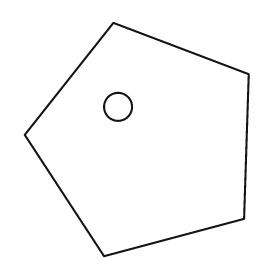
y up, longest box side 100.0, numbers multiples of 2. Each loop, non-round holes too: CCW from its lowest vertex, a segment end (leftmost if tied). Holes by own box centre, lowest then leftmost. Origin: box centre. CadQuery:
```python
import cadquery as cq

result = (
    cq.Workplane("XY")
    .moveTo(-14.0, -50.0)
    .lineTo(46.0, -34.0)
    .lineTo(48.0, 28.0)
    .lineTo(-10.0, 50.0)
    .lineTo(-48.0, 2.0)
    .close()
    .moveTo(-8.0, 14.0)
    .circle(6.0)
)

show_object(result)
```